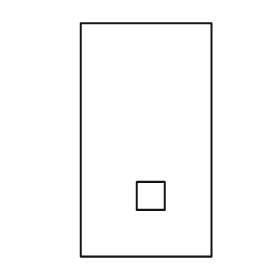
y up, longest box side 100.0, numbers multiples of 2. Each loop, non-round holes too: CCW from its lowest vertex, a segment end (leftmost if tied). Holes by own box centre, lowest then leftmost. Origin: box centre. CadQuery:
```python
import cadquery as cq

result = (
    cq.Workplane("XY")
    .moveTo(-28.0, -50.0)
    .lineTo(28.0, -50.0)
    .lineTo(28.0, 50.0)
    .lineTo(-28.0, 50.0)
    .close()
    .moveTo(-4.0, -30.0)
    .lineTo(8.0, -30.0)
    .lineTo(8.0, -18.0)
    .lineTo(-4.0, -18.0)
    .close()
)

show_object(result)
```